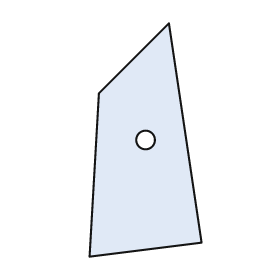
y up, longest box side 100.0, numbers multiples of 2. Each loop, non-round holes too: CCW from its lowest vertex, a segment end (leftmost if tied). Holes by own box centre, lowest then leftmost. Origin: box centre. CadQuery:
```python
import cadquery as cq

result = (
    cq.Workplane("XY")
    .moveTo(-24.0, -50.0)
    .lineTo(24.0, -44.0)
    .lineTo(10.0, 50.0)
    .lineTo(-20.0, 20.0)
    .close()
    .moveTo(0.0, 0.0)
    .circle(4.0)
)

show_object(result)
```